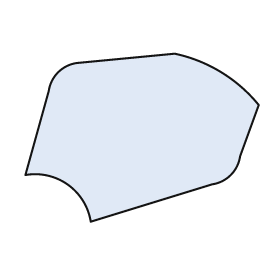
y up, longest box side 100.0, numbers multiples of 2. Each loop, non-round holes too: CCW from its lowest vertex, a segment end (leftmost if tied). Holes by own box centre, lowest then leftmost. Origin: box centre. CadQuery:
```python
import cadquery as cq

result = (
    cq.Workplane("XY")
    .moveTo(-22.0, -36.0)
    .lineTo(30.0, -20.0)
    .threePointArc((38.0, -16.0), (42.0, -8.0))
    .lineTo(50.0, 14.0)
    .threePointArc((34.0, 28.0), (14.0, 36.0))
    .lineTo(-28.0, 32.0)
    .threePointArc((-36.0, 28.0), (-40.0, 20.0))
    .lineTo(-50.0, -16.0)
    .threePointArc((-32.0, -20.0), (-22.0, -36.0))
    .close()
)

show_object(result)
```